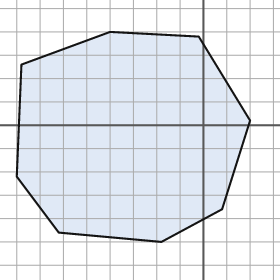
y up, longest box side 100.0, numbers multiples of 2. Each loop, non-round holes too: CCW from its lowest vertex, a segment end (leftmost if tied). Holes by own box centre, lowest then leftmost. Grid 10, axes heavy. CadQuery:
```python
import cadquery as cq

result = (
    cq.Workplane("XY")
    .moveTo(-18.0, -50.0)
    .lineTo(8.0, -36.0)
    .lineTo(20.0, 2.0)
    .lineTo(-2.0, 38.0)
    .lineTo(-40.0, 40.0)
    .lineTo(-78.0, 26.0)
    .lineTo(-80.0, -22.0)
    .lineTo(-62.0, -46.0)
    .close()
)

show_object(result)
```